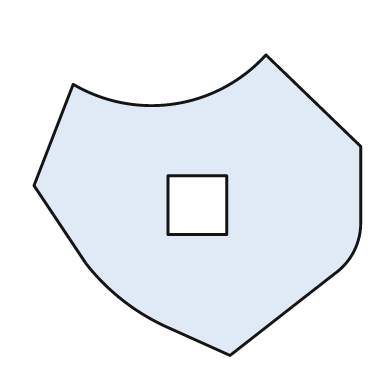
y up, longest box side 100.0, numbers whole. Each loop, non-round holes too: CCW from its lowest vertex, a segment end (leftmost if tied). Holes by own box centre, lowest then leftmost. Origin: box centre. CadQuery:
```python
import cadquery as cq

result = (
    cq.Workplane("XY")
    .moveTo(10.0, -46.0)
    .lineTo(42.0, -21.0)
    .threePointArc((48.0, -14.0), (50.0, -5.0))
    .lineTo(50.0, 18.0)
    .lineTo(21.0, 46.0)
    .threePointArc((-7.0, 31.0), (-38.0, 37.0))
    .lineTo(-50.0, 6.0)
    .lineTo(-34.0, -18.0)
    .threePointArc((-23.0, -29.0), (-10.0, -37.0))
    .close()
    .moveTo(-9.0, -9.0)
    .lineTo(9.0, -9.0)
    .lineTo(9.0, 9.0)
    .lineTo(-9.0, 9.0)
    .close()
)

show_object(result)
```